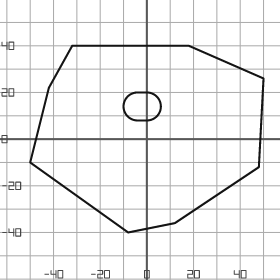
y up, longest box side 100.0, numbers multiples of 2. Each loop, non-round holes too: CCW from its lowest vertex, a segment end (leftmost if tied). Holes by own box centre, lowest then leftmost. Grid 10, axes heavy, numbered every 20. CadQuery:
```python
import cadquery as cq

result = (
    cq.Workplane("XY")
    .moveTo(-8.0, -40.0)
    .lineTo(12.0, -36.0)
    .lineTo(48.0, -12.0)
    .lineTo(50.0, 26.0)
    .lineTo(18.0, 40.0)
    .lineTo(-32.0, 40.0)
    .lineTo(-42.0, 22.0)
    .lineTo(-50.0, -10.0)
    .close()
    .moveTo(-4.0, 8.0)
    .lineTo(0.0, 8.0)
    .threePointArc((6.0, 14.0), (0.0, 20.0))
    .lineTo(-4.0, 20.0)
    .threePointArc((-10.0, 14.0), (-4.0, 8.0))
    .close()
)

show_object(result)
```